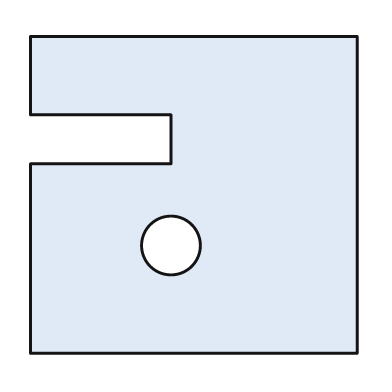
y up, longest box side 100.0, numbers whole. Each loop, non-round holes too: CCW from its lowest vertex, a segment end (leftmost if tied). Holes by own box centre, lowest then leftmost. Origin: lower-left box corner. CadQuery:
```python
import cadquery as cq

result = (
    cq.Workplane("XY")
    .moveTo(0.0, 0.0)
    .lineTo(100.0, 0.0)
    .lineTo(100.0, 97.0)
    .lineTo(0.0, 97.0)
    .lineTo(0.0, 73.0)
    .lineTo(43.0, 73.0)
    .lineTo(43.0, 58.0)
    .lineTo(0.0, 58.0)
    .close()
    .moveTo(43.0, 33.0)
    .circle(9.0)
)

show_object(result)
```